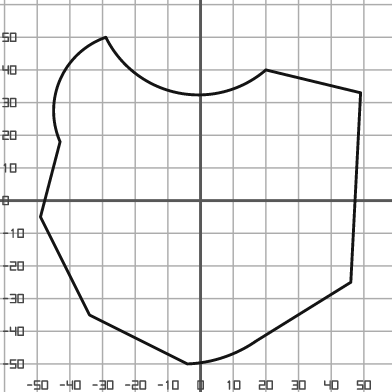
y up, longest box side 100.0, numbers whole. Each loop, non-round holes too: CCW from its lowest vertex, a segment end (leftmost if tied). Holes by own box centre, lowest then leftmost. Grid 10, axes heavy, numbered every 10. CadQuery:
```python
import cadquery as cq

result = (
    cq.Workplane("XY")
    .moveTo(-4.0, -50.0)
    .threePointArc((7.0, -48.0), (17.0, -43.0))
    .lineTo(46.0, -25.0)
    .lineTo(49.0, 33.0)
    .lineTo(20.0, 40.0)
    .threePointArc((-7.0, 33.0), (-29.0, 50.0))
    .threePointArc((-43.0, 37.0), (-43.0, 18.0))
    .lineTo(-49.0, -5.0)
    .lineTo(-34.0, -35.0)
    .close()
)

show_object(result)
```